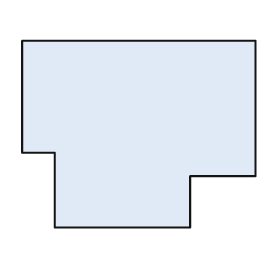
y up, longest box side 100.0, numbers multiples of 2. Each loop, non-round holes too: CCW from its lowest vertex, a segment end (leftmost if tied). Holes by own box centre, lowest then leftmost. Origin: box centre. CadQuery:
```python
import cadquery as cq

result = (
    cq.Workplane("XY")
    .moveTo(-36.0, -40.0)
    .lineTo(22.0, -40.0)
    .lineTo(22.0, -18.0)
    .lineTo(50.0, -18.0)
    .lineTo(50.0, 40.0)
    .lineTo(-50.0, 40.0)
    .lineTo(-50.0, -8.0)
    .lineTo(-36.0, -8.0)
    .close()
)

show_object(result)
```